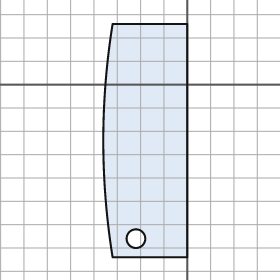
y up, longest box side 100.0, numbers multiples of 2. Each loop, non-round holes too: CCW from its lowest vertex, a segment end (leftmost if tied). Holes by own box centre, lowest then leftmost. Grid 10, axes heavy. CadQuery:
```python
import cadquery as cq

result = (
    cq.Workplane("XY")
    .moveTo(-32.0, -74.0)
    .lineTo(0.0, -74.0)
    .lineTo(0.0, 26.0)
    .lineTo(-32.0, 26.0)
    .threePointArc((-36.0, -24.0), (-32.0, -74.0))
    .close()
    .moveTo(-22.0, -66.0)
    .circle(4.0)
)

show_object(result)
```